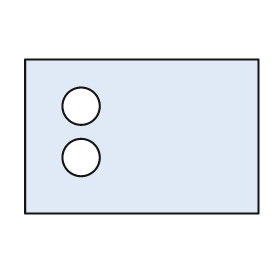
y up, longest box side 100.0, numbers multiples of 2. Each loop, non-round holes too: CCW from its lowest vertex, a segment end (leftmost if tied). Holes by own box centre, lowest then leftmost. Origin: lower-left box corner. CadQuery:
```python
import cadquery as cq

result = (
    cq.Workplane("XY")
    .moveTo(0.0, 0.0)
    .lineTo(100.0, 0.0)
    .lineTo(100.0, 66.0)
    .lineTo(0.0, 66.0)
    .close()
    .moveTo(24.0, 24.0)
    .circle(8.0)
    .moveTo(24.0, 46.0)
    .circle(8.0)
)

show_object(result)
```